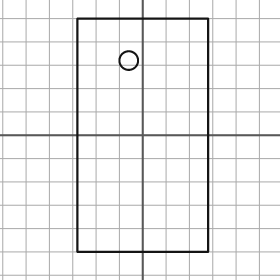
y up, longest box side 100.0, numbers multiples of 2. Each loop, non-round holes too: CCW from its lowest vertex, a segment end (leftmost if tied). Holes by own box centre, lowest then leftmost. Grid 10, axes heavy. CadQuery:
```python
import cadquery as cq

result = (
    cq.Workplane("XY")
    .moveTo(-28.0, -50.0)
    .lineTo(28.0, -50.0)
    .lineTo(28.0, 50.0)
    .lineTo(-28.0, 50.0)
    .close()
    .moveTo(-6.0, 32.0)
    .circle(4.0)
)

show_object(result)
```